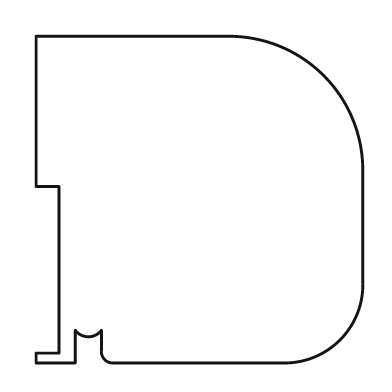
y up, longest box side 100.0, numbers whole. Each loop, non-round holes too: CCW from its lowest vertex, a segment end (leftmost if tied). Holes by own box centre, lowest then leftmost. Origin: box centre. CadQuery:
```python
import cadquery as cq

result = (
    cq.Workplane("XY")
    .moveTo(-50.0, -50.0)
    .lineTo(-38.0, -50.0)
    .lineTo(-38.0, -40.0)
    .threePointArc((-34.0, -42.0), (-30.0, -40.0))
    .lineTo(-30.0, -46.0)
    .threePointArc((-29.0, -49.0), (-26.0, -50.0))
    .lineTo(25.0, -50.0)
    .threePointArc((43.0, -43.0), (50.0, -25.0))
    .lineTo(50.0, 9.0)
    .threePointArc((38.0, 38.0), (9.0, 50.0))
    .lineTo(-50.0, 50.0)
    .lineTo(-50.0, 4.0)
    .lineTo(-43.0, 4.0)
    .lineTo(-43.0, -47.0)
    .lineTo(-50.0, -47.0)
    .close()
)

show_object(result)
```